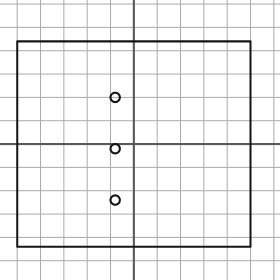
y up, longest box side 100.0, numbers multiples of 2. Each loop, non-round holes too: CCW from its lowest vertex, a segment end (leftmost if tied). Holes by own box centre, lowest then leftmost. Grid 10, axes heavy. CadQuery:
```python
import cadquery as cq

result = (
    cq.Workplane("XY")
    .moveTo(-50.0, -44.0)
    .lineTo(50.0, -44.0)
    .lineTo(50.0, 44.0)
    .lineTo(-50.0, 44.0)
    .close()
    .moveTo(-8.0, -24.0)
    .circle(2.0)
    .moveTo(-8.0, -2.0)
    .circle(2.0)
    .moveTo(-8.0, 20.0)
    .circle(2.0)
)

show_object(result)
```